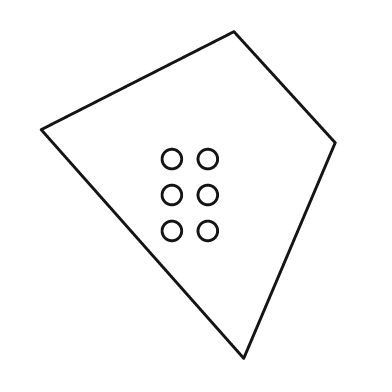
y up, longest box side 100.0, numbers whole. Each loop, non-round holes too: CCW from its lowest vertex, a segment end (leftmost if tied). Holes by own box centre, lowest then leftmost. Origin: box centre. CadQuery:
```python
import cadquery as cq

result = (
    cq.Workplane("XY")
    .moveTo(17.0, -50.0)
    .lineTo(45.0, 16.0)
    .lineTo(14.0, 50.0)
    .lineTo(-45.0, 20.0)
    .close()
    .moveTo(-5.0, -11.0)
    .circle(3.0)
    .moveTo(6.0, -11.0)
    .circle(3.0)
    .moveTo(-5.0, 0.0)
    .circle(3.0)
    .moveTo(6.0, 0.0)
    .circle(3.0)
    .moveTo(-5.0, 11.0)
    .circle(3.0)
    .moveTo(6.0, 11.0)
    .circle(3.0)
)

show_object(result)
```